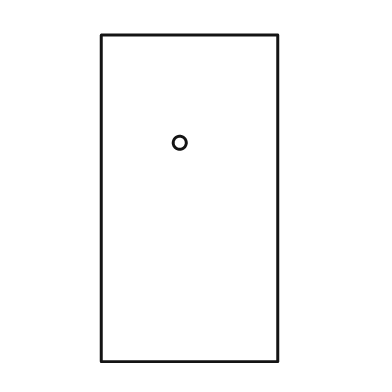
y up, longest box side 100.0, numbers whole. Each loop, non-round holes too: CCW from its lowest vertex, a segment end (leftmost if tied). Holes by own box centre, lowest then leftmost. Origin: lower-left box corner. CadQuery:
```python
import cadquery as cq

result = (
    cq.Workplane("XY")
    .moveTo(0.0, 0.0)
    .lineTo(54.0, 0.0)
    .lineTo(54.0, 100.0)
    .lineTo(0.0, 100.0)
    .close()
    .moveTo(24.0, 67.0)
    .circle(2.0)
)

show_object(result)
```